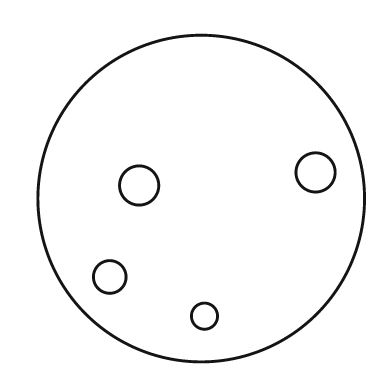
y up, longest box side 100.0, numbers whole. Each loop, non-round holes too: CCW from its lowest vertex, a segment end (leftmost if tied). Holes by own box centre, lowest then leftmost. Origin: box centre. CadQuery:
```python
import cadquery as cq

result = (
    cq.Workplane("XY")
    .moveTo(0.0, 0.0)
    .circle(50.0)
    .moveTo(1.0, -36.0)
    .circle(4.0)
    .moveTo(-28.0, -24.0)
    .circle(5.0)
    .moveTo(-19.0, 4.0)
    .circle(6.0)
    .moveTo(35.0, 8.0)
    .circle(6.0)
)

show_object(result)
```